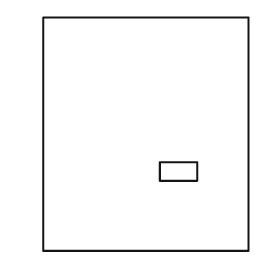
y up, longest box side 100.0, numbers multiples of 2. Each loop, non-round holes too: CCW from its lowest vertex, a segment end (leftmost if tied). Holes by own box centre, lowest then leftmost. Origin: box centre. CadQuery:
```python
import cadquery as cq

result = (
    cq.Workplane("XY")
    .moveTo(-44.0, -50.0)
    .lineTo(44.0, -50.0)
    .lineTo(44.0, 50.0)
    .lineTo(-44.0, 50.0)
    .close()
    .moveTo(6.0, -20.0)
    .lineTo(22.0, -20.0)
    .lineTo(22.0, -12.0)
    .lineTo(6.0, -12.0)
    .close()
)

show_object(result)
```